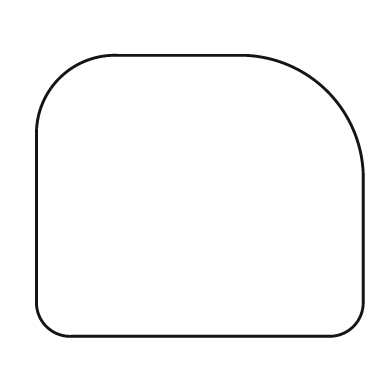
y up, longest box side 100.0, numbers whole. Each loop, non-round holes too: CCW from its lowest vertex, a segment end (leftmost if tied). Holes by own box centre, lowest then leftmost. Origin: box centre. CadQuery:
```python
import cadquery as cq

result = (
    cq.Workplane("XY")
    .moveTo(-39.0, -43.0)
    .lineTo(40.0, -43.0)
    .threePointArc((47.0, -40.0), (50.0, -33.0))
    .lineTo(50.0, 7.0)
    .threePointArc((39.0, 32.0), (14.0, 43.0))
    .lineTo(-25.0, 43.0)
    .threePointArc((-43.0, 36.0), (-50.0, 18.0))
    .lineTo(-50.0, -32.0)
    .threePointArc((-47.0, -40.0), (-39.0, -43.0))
    .close()
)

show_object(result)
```